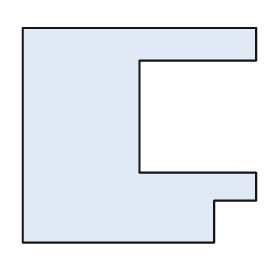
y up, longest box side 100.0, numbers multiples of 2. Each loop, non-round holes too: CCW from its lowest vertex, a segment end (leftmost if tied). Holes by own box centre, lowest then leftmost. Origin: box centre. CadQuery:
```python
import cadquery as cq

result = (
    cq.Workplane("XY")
    .moveTo(-50.0, -46.0)
    .lineTo(32.0, -46.0)
    .lineTo(32.0, -28.0)
    .lineTo(50.0, -28.0)
    .lineTo(50.0, -16.0)
    .lineTo(0.0, -16.0)
    .lineTo(0.0, 32.0)
    .lineTo(50.0, 32.0)
    .lineTo(50.0, 46.0)
    .lineTo(-50.0, 46.0)
    .close()
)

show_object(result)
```